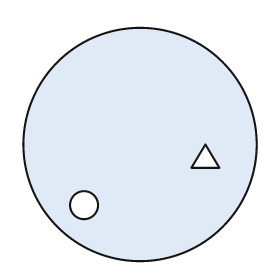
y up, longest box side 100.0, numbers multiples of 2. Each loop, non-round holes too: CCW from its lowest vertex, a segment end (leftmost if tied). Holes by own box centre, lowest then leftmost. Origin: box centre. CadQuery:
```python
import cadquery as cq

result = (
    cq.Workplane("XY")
    .moveTo(0.0, 0.0)
    .circle(50.0)
    .moveTo(-24.0, -26.0)
    .circle(6.0)
    .moveTo(22.0, -10.0)
    .lineTo(34.0, -10.0)
    .lineTo(28.0, 0.0)
    .close()
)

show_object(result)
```